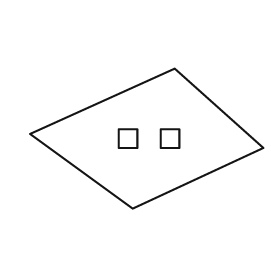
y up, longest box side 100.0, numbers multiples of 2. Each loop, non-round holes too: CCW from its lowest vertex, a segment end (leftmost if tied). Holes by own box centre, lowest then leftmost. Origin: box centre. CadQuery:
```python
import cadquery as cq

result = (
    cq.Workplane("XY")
    .moveTo(-6.0, -30.0)
    .lineTo(50.0, -4.0)
    .lineTo(12.0, 30.0)
    .lineTo(-50.0, 2.0)
    .close()
    .moveTo(-12.0, -4.0)
    .lineTo(-4.0, -4.0)
    .lineTo(-4.0, 4.0)
    .lineTo(-12.0, 4.0)
    .close()
    .moveTo(6.0, -4.0)
    .lineTo(14.0, -4.0)
    .lineTo(14.0, 4.0)
    .lineTo(6.0, 4.0)
    .close()
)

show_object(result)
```